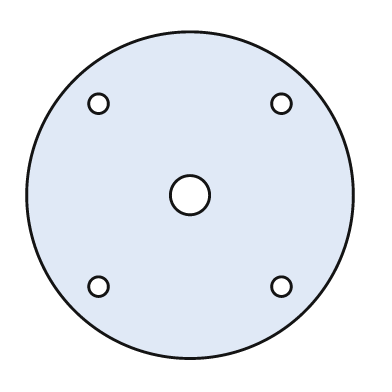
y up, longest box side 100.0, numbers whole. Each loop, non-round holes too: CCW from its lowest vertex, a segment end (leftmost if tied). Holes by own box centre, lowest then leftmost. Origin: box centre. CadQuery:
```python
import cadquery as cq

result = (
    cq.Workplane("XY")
    .moveTo(0.0, 0.0)
    .circle(50.0)
    .moveTo(-28.0, -28.0)
    .circle(3.0)
    .moveTo(28.0, -28.0)
    .circle(3.0)
    .moveTo(0.0, 0.0)
    .circle(6.0)
    .moveTo(-28.0, 28.0)
    .circle(3.0)
    .moveTo(28.0, 28.0)
    .circle(3.0)
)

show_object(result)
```